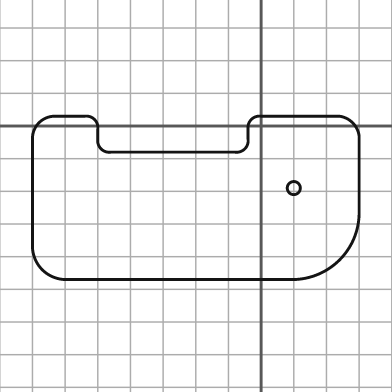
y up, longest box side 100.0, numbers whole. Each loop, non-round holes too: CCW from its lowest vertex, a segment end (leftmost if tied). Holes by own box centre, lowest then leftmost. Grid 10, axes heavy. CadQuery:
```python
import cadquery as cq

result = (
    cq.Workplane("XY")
    .moveTo(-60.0, -47.0)
    .lineTo(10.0, -47.0)
    .threePointArc((24.0, -41.0), (30.0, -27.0))
    .lineTo(30.0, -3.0)
    .threePointArc((28.0, 1.0), (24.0, 3.0))
    .lineTo(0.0, 3.0)
    .threePointArc((-3.0, 2.0), (-4.0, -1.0))
    .lineTo(-4.0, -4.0)
    .threePointArc((-5.0, -7.0), (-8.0, -8.0))
    .lineTo(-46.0, -8.0)
    .threePointArc((-49.0, -7.0), (-50.0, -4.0))
    .lineTo(-50.0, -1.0)
    .threePointArc((-51.0, 2.0), (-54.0, 3.0))
    .lineTo(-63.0, 3.0)
    .threePointArc((-68.0, 1.0), (-70.0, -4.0))
    .lineTo(-70.0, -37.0)
    .threePointArc((-67.0, -44.0), (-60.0, -47.0))
    .close()
    .moveTo(10.0, -19.0)
    .circle(2.0)
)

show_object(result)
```